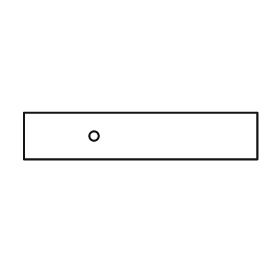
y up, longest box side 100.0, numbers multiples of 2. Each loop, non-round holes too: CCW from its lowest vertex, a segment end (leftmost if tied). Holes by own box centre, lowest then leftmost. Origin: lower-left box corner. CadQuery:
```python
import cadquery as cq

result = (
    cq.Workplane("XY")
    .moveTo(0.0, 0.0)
    .lineTo(100.0, 0.0)
    .lineTo(100.0, 20.0)
    .lineTo(0.0, 20.0)
    .close()
    .moveTo(30.0, 10.0)
    .circle(2.0)
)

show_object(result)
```